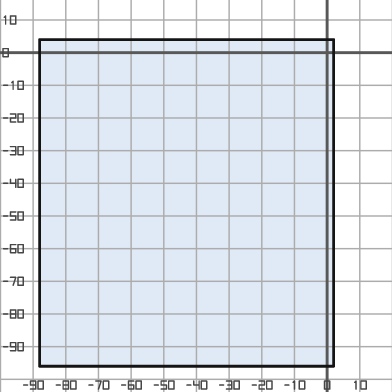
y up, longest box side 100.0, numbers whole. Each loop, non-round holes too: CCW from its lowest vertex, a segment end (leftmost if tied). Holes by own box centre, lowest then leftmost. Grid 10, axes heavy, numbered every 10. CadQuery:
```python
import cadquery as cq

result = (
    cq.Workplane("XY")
    .moveTo(-88.0, -96.0)
    .lineTo(2.0, -96.0)
    .lineTo(2.0, 4.0)
    .lineTo(-88.0, 4.0)
    .close()
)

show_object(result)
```